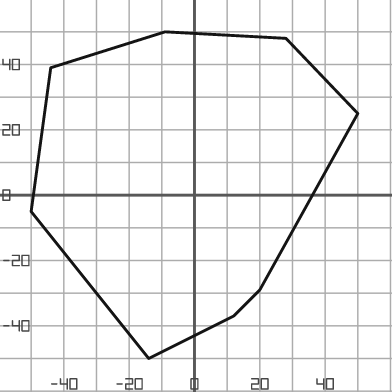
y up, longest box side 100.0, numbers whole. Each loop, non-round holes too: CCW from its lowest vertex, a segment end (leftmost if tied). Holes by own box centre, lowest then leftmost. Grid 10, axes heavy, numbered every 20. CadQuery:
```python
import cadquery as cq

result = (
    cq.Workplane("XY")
    .moveTo(-14.0, -50.0)
    .lineTo(12.0, -37.0)
    .lineTo(20.0, -29.0)
    .lineTo(50.0, 25.0)
    .lineTo(28.0, 48.0)
    .lineTo(-9.0, 50.0)
    .lineTo(-44.0, 39.0)
    .lineTo(-50.0, -5.0)
    .close()
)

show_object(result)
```